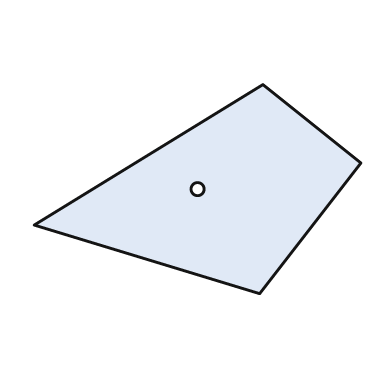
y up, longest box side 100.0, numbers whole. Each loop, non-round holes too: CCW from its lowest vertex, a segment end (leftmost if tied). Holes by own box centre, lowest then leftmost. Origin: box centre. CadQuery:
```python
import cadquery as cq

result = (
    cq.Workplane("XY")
    .moveTo(19.0, -32.0)
    .lineTo(50.0, 8.0)
    .lineTo(20.0, 32.0)
    .lineTo(-50.0, -11.0)
    .close()
    .moveTo(0.0, 0.0)
    .circle(2.0)
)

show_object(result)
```